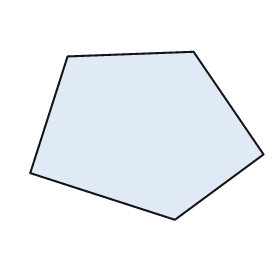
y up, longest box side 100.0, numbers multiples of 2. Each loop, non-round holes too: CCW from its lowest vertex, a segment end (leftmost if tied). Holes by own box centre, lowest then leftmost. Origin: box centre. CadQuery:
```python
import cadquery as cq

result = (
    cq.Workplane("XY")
    .moveTo(12.0, -36.0)
    .lineTo(50.0, -8.0)
    .lineTo(20.0, 36.0)
    .lineTo(-34.0, 34.0)
    .lineTo(-50.0, -16.0)
    .close()
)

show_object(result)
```